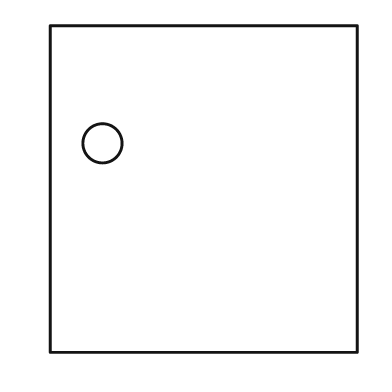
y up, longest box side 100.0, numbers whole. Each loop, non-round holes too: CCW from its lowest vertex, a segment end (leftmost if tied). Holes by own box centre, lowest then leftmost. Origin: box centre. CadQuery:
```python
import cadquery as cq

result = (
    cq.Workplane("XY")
    .moveTo(-47.0, -50.0)
    .lineTo(47.0, -50.0)
    .lineTo(47.0, 50.0)
    .lineTo(-47.0, 50.0)
    .close()
    .moveTo(-31.0, 14.0)
    .circle(6.0)
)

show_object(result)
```